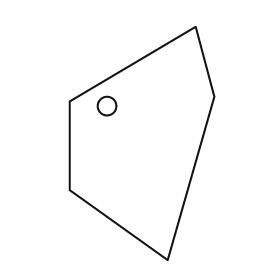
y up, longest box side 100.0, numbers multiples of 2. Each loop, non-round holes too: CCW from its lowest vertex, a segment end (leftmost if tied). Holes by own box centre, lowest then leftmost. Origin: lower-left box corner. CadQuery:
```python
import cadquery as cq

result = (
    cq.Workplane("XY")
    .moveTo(42.0, 0.0)
    .lineTo(62.0, 70.0)
    .lineTo(54.0, 100.0)
    .lineTo(0.0, 68.0)
    .lineTo(0.0, 30.0)
    .close()
    .moveTo(16.0, 66.0)
    .circle(4.0)
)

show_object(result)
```